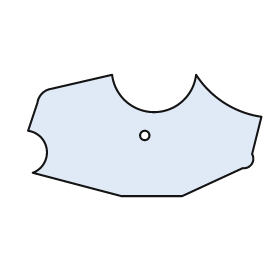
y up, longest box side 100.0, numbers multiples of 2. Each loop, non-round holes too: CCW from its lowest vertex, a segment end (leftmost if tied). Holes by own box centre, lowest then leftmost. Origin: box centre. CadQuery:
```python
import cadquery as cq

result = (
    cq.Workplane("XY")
    .moveTo(-10.0, -26.0)
    .lineTo(16.0, -26.0)
    .lineTo(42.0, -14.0)
    .threePointArc((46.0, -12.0), (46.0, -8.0))
    .lineTo(50.0, 8.0)
    .threePointArc((34.0, 14.0), (22.0, 26.0))
    .threePointArc((4.0, 10.0), (-14.0, 26.0))
    .lineTo(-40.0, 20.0)
    .threePointArc((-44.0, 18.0), (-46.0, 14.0))
    .lineTo(-50.0, 2.0)
    .threePointArc((-42.0, -6.0), (-48.0, -16.0))
    .close()
    .moveTo(0.0, 0.0)
    .circle(2.0)
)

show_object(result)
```